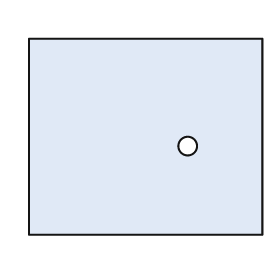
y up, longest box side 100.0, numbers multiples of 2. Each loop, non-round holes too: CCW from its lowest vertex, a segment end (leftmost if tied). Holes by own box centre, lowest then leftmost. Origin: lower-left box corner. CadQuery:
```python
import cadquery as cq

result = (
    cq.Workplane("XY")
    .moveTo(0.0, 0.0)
    .lineTo(100.0, 0.0)
    .lineTo(100.0, 84.0)
    .lineTo(0.0, 84.0)
    .close()
    .moveTo(68.0, 38.0)
    .circle(4.0)
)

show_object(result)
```